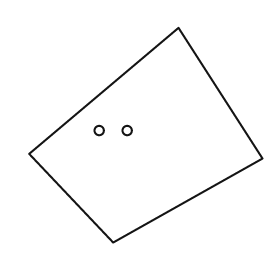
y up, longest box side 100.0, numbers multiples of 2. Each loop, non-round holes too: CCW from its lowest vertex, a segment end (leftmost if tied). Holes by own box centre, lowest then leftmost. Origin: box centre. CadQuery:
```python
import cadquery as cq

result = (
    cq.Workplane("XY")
    .moveTo(-14.0, -46.0)
    .lineTo(50.0, -10.0)
    .lineTo(14.0, 46.0)
    .lineTo(-50.0, -8.0)
    .close()
    .moveTo(-20.0, 2.0)
    .circle(2.0)
    .moveTo(-8.0, 2.0)
    .circle(2.0)
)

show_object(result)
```